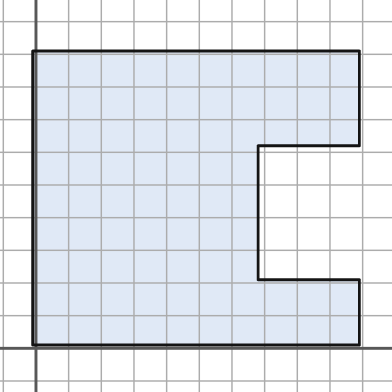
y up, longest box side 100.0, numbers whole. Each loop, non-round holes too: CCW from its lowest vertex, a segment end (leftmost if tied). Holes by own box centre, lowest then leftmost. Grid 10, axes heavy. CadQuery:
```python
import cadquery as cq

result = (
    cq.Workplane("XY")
    .moveTo(-1.0, 1.0)
    .lineTo(99.0, 1.0)
    .lineTo(99.0, 21.0)
    .lineTo(68.0, 21.0)
    .lineTo(68.0, 62.0)
    .lineTo(99.0, 62.0)
    .lineTo(99.0, 91.0)
    .lineTo(-1.0, 91.0)
    .close()
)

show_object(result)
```